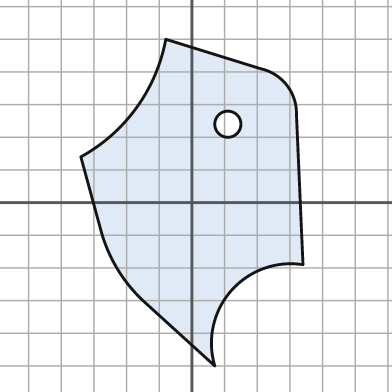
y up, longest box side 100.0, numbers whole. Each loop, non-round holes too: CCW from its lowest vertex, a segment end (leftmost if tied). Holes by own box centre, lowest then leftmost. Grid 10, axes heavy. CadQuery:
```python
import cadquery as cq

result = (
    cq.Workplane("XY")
    .moveTo(7.0, -50.0)
    .threePointArc((12.0, -27.0), (34.0, -19.0))
    .lineTo(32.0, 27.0)
    .threePointArc((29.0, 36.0), (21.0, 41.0))
    .lineTo(-8.0, 50.0)
    .threePointArc((-17.0, 29.0), (-34.0, 14.0))
    .lineTo(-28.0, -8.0)
    .threePointArc((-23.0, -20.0), (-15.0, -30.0))
    .close()
    .moveTo(11.0, 24.0)
    .circle(4.0)
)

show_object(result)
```